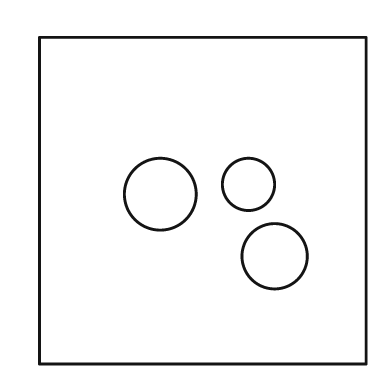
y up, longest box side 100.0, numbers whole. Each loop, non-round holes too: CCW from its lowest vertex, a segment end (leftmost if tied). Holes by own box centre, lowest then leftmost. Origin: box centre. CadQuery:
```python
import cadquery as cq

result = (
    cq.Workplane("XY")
    .moveTo(-50.0, -50.0)
    .lineTo(50.0, -50.0)
    .lineTo(50.0, 50.0)
    .lineTo(-50.0, 50.0)
    .close()
    .moveTo(22.0, -17.0)
    .circle(10.0)
    .moveTo(-13.0, 2.0)
    .circle(11.0)
    .moveTo(14.0, 5.0)
    .circle(8.0)
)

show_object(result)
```